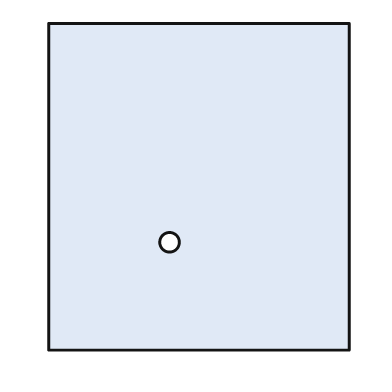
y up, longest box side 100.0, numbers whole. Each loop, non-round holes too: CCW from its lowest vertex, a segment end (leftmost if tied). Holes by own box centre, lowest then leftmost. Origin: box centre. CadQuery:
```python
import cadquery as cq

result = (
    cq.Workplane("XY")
    .moveTo(-46.0, -50.0)
    .lineTo(46.0, -50.0)
    .lineTo(46.0, 50.0)
    .lineTo(-46.0, 50.0)
    .close()
    .moveTo(-9.0, -17.0)
    .circle(3.0)
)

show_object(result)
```